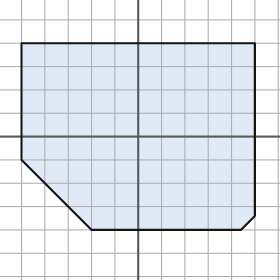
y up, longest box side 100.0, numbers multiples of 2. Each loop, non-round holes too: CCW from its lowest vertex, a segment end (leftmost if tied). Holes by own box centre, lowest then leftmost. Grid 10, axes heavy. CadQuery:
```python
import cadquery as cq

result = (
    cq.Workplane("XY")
    .moveTo(-20.0, -40.0)
    .lineTo(44.0, -40.0)
    .lineTo(50.0, -34.0)
    .lineTo(50.0, 40.0)
    .lineTo(-50.0, 40.0)
    .lineTo(-50.0, -10.0)
    .close()
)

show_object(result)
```